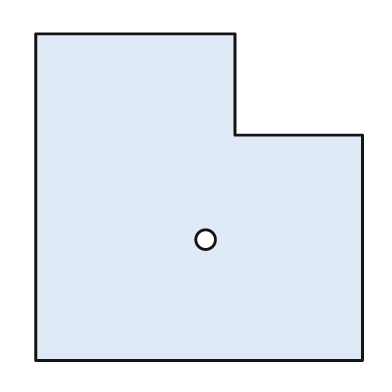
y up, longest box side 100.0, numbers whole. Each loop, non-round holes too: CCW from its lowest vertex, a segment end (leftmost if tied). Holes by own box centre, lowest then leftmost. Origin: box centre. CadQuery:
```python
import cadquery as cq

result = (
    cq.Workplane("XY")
    .moveTo(-50.0, -50.0)
    .lineTo(50.0, -50.0)
    .lineTo(50.0, 19.0)
    .lineTo(11.0, 19.0)
    .lineTo(11.0, 50.0)
    .lineTo(-50.0, 50.0)
    .close()
    .moveTo(2.0, -13.0)
    .circle(3.0)
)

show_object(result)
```